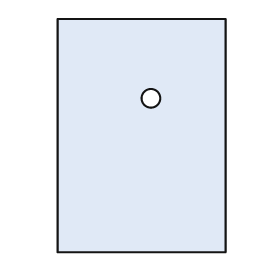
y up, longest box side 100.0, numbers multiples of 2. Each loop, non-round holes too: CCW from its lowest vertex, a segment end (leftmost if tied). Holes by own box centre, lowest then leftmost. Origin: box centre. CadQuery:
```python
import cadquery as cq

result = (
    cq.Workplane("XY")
    .moveTo(-36.0, -50.0)
    .lineTo(36.0, -50.0)
    .lineTo(36.0, 50.0)
    .lineTo(-36.0, 50.0)
    .close()
    .moveTo(4.0, 16.0)
    .circle(4.0)
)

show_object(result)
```